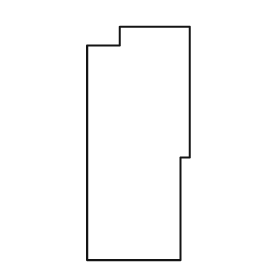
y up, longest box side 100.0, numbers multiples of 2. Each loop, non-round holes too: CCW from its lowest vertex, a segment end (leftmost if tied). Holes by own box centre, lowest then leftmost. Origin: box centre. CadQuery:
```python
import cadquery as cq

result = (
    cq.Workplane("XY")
    .moveTo(-22.0, -50.0)
    .lineTo(18.0, -50.0)
    .lineTo(18.0, -6.0)
    .lineTo(22.0, -6.0)
    .lineTo(22.0, 50.0)
    .lineTo(-8.0, 50.0)
    .lineTo(-8.0, 42.0)
    .lineTo(-22.0, 42.0)
    .close()
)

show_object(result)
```